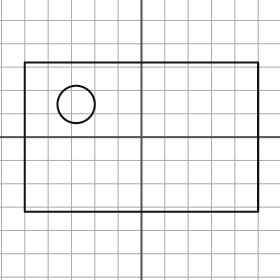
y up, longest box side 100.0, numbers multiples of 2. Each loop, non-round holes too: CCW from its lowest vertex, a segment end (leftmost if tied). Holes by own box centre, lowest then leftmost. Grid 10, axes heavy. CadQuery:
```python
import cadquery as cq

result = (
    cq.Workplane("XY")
    .moveTo(-50.0, -32.0)
    .lineTo(50.0, -32.0)
    .lineTo(50.0, 32.0)
    .lineTo(-50.0, 32.0)
    .close()
    .moveTo(-28.0, 14.0)
    .circle(8.0)
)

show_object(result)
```